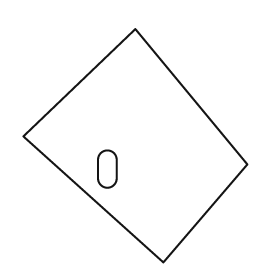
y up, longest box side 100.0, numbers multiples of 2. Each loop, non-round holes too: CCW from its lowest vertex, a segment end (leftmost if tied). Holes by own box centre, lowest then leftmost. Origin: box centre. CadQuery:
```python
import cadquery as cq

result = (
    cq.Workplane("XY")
    .moveTo(12.0, -50.0)
    .lineTo(48.0, -8.0)
    .lineTo(0.0, 50.0)
    .lineTo(-48.0, 4.0)
    .close()
    .moveTo(-16.0, -14.0)
    .threePointArc((-12.0, -18.0), (-8.0, -14.0))
    .lineTo(-8.0, -6.0)
    .threePointArc((-12.0, -2.0), (-16.0, -6.0))
    .close()
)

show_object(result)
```